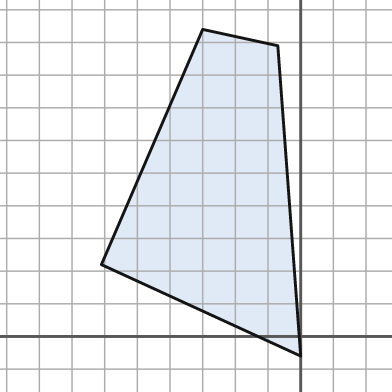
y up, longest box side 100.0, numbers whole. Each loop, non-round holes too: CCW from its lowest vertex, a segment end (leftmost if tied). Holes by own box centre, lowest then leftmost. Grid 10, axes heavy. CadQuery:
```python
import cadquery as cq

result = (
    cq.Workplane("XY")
    .moveTo(0.0, -6.0)
    .lineTo(-7.0, 89.0)
    .lineTo(-30.0, 94.0)
    .lineTo(-61.0, 22.0)
    .close()
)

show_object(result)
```